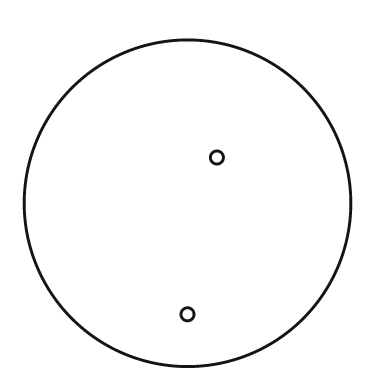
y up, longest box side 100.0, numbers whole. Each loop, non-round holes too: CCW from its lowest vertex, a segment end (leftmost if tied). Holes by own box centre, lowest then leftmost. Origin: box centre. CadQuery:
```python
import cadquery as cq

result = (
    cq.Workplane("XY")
    .moveTo(0.0, 0.0)
    .circle(50.0)
    .moveTo(0.0, -34.0)
    .circle(2.0)
    .moveTo(9.0, 14.0)
    .circle(2.0)
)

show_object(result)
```